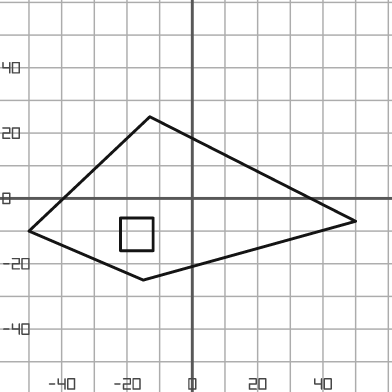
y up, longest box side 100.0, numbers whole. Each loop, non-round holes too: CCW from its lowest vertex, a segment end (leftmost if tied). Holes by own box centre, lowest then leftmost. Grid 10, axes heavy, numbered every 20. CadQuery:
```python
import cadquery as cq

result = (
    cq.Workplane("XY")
    .moveTo(-15.0, -25.0)
    .lineTo(50.0, -7.0)
    .lineTo(-13.0, 25.0)
    .lineTo(-50.0, -10.0)
    .close()
    .moveTo(-22.0, -16.0)
    .lineTo(-12.0, -16.0)
    .lineTo(-12.0, -6.0)
    .lineTo(-22.0, -6.0)
    .close()
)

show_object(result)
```